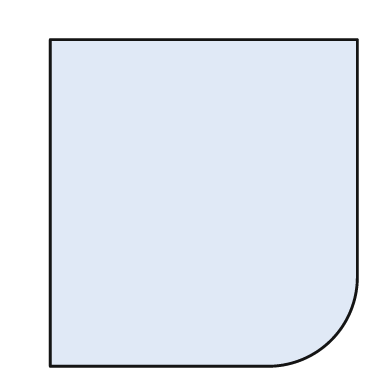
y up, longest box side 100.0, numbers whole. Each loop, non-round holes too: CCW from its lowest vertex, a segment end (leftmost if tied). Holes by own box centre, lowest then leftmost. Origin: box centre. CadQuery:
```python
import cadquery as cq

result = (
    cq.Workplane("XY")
    .moveTo(-47.0, -50.0)
    .lineTo(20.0, -50.0)
    .threePointArc((39.0, -42.0), (47.0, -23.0))
    .lineTo(47.0, 50.0)
    .lineTo(-47.0, 50.0)
    .close()
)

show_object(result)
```